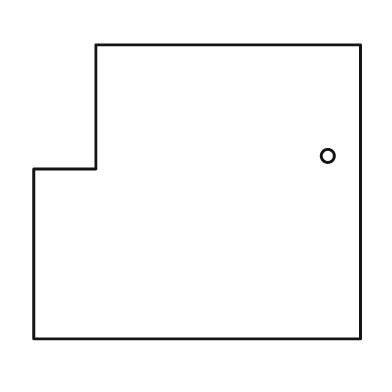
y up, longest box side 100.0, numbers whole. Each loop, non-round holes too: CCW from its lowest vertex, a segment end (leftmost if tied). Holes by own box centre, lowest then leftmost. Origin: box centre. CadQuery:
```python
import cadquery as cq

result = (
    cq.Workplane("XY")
    .moveTo(-50.0, -45.0)
    .lineTo(50.0, -45.0)
    .lineTo(50.0, 45.0)
    .lineTo(-31.0, 45.0)
    .lineTo(-31.0, 7.0)
    .lineTo(-50.0, 7.0)
    .close()
    .moveTo(40.0, 11.0)
    .circle(2.0)
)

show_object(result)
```